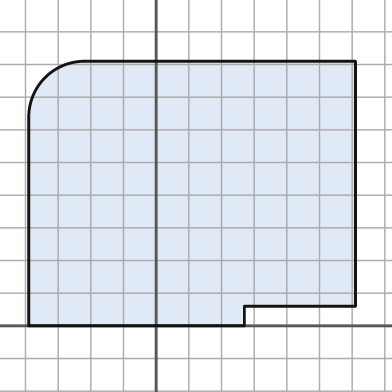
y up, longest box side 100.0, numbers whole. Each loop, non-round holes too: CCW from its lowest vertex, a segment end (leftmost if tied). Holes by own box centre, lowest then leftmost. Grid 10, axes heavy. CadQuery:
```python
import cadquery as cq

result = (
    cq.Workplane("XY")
    .moveTo(-39.0, 0.0)
    .lineTo(27.0, 0.0)
    .lineTo(27.0, 6.0)
    .lineTo(61.0, 6.0)
    .lineTo(61.0, 81.0)
    .lineTo(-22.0, 81.0)
    .threePointArc((-34.0, 76.0), (-39.0, 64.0))
    .close()
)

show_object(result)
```